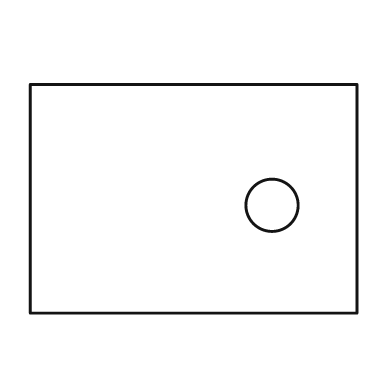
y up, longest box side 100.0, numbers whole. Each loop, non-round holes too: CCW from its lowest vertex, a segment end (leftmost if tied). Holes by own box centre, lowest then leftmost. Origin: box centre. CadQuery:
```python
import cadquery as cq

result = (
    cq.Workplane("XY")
    .moveTo(-50.0, -35.0)
    .lineTo(50.0, -35.0)
    .lineTo(50.0, 35.0)
    .lineTo(-50.0, 35.0)
    .close()
    .moveTo(24.0, -2.0)
    .circle(8.0)
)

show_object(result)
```